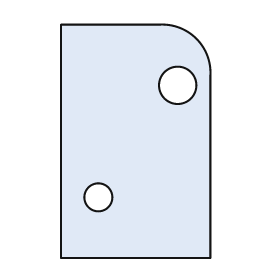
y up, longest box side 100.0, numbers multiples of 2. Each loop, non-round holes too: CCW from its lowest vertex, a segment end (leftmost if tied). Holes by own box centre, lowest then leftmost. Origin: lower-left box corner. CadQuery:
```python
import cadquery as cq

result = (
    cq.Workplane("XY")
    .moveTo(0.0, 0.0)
    .lineTo(64.0, 0.0)
    .lineTo(64.0, 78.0)
    .threePointArc((58.0, 94.0), (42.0, 100.0))
    .lineTo(0.0, 100.0)
    .close()
    .moveTo(16.0, 26.0)
    .circle(6.0)
    .moveTo(50.0, 74.0)
    .circle(8.0)
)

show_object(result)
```